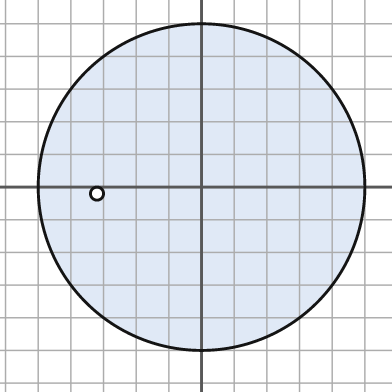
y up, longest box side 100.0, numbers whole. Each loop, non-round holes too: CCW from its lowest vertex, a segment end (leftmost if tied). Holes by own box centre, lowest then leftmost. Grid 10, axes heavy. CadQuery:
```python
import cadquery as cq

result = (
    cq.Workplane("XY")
    .moveTo(0.0, 0.0)
    .circle(50.0)
    .moveTo(-32.0, -2.0)
    .circle(2.0)
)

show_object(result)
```